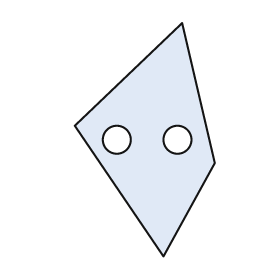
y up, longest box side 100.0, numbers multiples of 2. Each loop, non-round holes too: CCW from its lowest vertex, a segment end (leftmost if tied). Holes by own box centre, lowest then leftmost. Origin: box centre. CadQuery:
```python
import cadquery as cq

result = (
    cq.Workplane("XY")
    .moveTo(8.0, -50.0)
    .lineTo(30.0, -10.0)
    .lineTo(16.0, 50.0)
    .lineTo(-30.0, 6.0)
    .close()
    .moveTo(-12.0, 0.0)
    .circle(6.0)
    .moveTo(14.0, 0.0)
    .circle(6.0)
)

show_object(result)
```